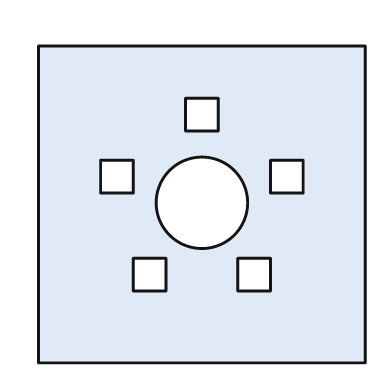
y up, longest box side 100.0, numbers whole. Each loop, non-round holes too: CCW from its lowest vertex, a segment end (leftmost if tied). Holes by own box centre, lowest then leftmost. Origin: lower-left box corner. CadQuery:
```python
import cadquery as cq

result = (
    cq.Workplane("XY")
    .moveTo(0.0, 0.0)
    .lineTo(100.0, 0.0)
    .lineTo(100.0, 97.0)
    .lineTo(0.0, 97.0)
    .close()
    .moveTo(29.0, 22.0)
    .lineTo(39.0, 22.0)
    .lineTo(39.0, 32.0)
    .lineTo(29.0, 32.0)
    .close()
    .moveTo(61.0, 22.0)
    .lineTo(71.0, 22.0)
    .lineTo(71.0, 32.0)
    .lineTo(61.0, 32.0)
    .close()
    .moveTo(50.0, 49.0)
    .circle(14.0)
    .moveTo(19.0, 52.0)
    .lineTo(29.0, 52.0)
    .lineTo(29.0, 62.0)
    .lineTo(19.0, 62.0)
    .close()
    .moveTo(71.0, 52.0)
    .lineTo(81.0, 52.0)
    .lineTo(81.0, 62.0)
    .lineTo(71.0, 62.0)
    .close()
    .moveTo(45.0, 71.0)
    .lineTo(55.0, 71.0)
    .lineTo(55.0, 81.0)
    .lineTo(45.0, 81.0)
    .close()
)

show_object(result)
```